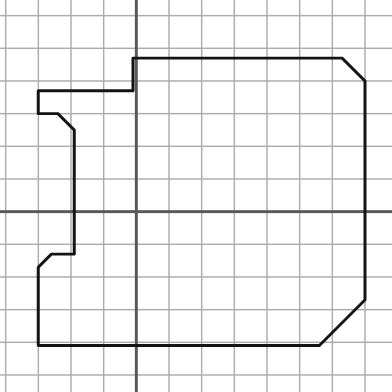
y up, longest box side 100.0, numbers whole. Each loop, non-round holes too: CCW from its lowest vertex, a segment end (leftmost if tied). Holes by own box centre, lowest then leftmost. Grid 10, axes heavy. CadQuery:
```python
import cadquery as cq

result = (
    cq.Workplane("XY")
    .moveTo(-30.0, -41.0)
    .lineTo(56.0, -41.0)
    .lineTo(70.0, -27.0)
    .lineTo(70.0, 40.0)
    .lineTo(63.0, 47.0)
    .lineTo(-1.0, 47.0)
    .lineTo(-1.0, 37.0)
    .lineTo(-30.0, 37.0)
    .lineTo(-30.0, 30.0)
    .lineTo(-24.0, 30.0)
    .lineTo(-19.0, 25.0)
    .lineTo(-19.0, -13.0)
    .lineTo(-26.0, -13.0)
    .lineTo(-30.0, -17.0)
    .close()
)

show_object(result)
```